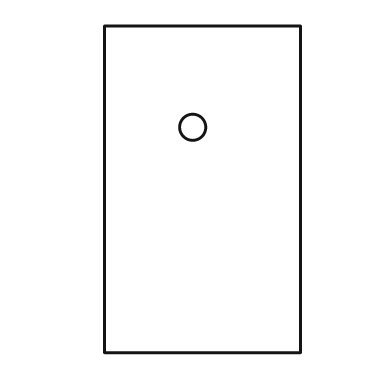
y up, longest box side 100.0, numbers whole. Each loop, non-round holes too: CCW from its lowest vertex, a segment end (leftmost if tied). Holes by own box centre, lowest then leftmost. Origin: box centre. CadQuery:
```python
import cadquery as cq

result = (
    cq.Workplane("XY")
    .moveTo(-30.0, -50.0)
    .lineTo(30.0, -50.0)
    .lineTo(30.0, 50.0)
    .lineTo(-30.0, 50.0)
    .close()
    .moveTo(-3.0, 19.0)
    .circle(4.0)
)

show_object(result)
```